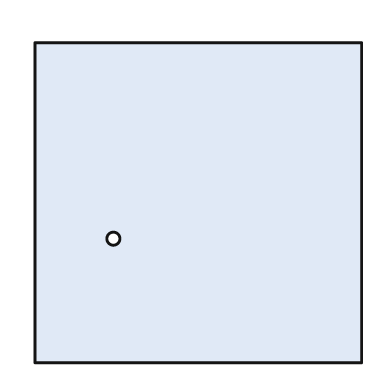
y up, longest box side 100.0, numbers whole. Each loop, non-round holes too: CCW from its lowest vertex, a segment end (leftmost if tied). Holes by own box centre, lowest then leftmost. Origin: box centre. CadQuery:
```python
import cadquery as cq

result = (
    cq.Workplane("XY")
    .moveTo(-50.0, -49.0)
    .lineTo(50.0, -49.0)
    .lineTo(50.0, 49.0)
    .lineTo(-50.0, 49.0)
    .close()
    .moveTo(-26.0, -11.0)
    .circle(2.0)
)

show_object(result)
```